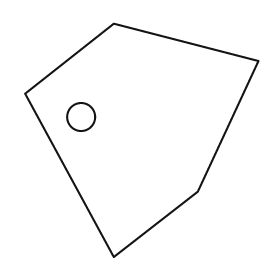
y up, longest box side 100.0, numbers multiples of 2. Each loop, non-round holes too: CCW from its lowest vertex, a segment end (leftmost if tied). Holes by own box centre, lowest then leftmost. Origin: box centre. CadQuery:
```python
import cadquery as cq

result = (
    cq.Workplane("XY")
    .moveTo(-12.0, -50.0)
    .lineTo(24.0, -22.0)
    .lineTo(50.0, 34.0)
    .lineTo(-12.0, 50.0)
    .lineTo(-50.0, 20.0)
    .close()
    .moveTo(-26.0, 10.0)
    .circle(6.0)
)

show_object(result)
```